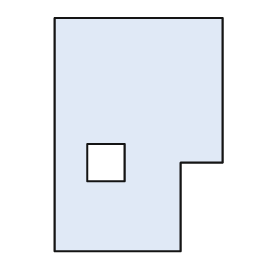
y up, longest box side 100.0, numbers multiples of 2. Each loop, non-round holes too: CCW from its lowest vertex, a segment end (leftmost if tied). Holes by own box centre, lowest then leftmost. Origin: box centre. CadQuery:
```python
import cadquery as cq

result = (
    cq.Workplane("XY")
    .moveTo(-36.0, -50.0)
    .lineTo(18.0, -50.0)
    .lineTo(18.0, -12.0)
    .lineTo(36.0, -12.0)
    .lineTo(36.0, 50.0)
    .lineTo(-36.0, 50.0)
    .close()
    .moveTo(-22.0, -20.0)
    .lineTo(-6.0, -20.0)
    .lineTo(-6.0, -4.0)
    .lineTo(-22.0, -4.0)
    .close()
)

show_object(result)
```